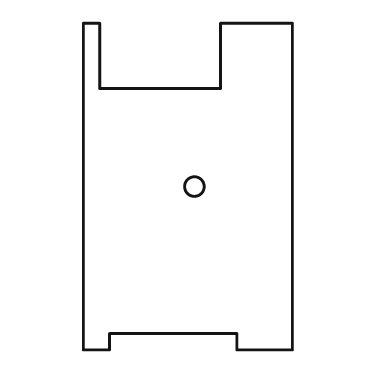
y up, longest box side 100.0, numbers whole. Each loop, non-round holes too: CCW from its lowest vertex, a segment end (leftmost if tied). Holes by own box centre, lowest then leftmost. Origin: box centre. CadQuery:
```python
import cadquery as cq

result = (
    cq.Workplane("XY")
    .moveTo(-32.0, -50.0)
    .lineTo(-24.0, -50.0)
    .lineTo(-24.0, -45.0)
    .lineTo(15.0, -45.0)
    .lineTo(15.0, -50.0)
    .lineTo(32.0, -50.0)
    .lineTo(32.0, 50.0)
    .lineTo(10.0, 50.0)
    .lineTo(10.0, 30.0)
    .lineTo(-27.0, 30.0)
    .lineTo(-27.0, 50.0)
    .lineTo(-32.0, 50.0)
    .close()
    .moveTo(2.0, 0.0)
    .circle(3.0)
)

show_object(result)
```